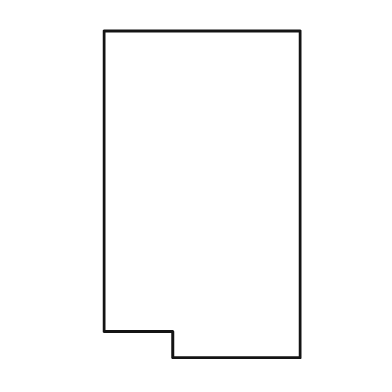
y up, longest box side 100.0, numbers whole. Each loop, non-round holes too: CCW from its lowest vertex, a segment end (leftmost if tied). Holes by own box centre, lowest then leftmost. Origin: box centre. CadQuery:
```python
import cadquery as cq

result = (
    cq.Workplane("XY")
    .moveTo(-9.0, -50.0)
    .lineTo(30.0, -50.0)
    .lineTo(30.0, 50.0)
    .lineTo(-30.0, 50.0)
    .lineTo(-30.0, -42.0)
    .lineTo(-9.0, -42.0)
    .close()
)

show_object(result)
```